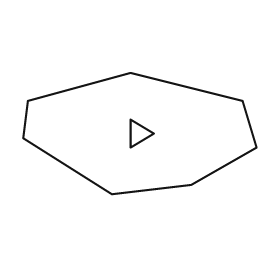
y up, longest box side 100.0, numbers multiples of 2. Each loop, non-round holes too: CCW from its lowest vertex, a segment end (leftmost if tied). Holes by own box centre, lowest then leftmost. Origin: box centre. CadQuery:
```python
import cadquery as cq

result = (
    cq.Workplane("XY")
    .moveTo(-12.0, -26.0)
    .lineTo(22.0, -22.0)
    .lineTo(50.0, -6.0)
    .lineTo(44.0, 14.0)
    .lineTo(-4.0, 26.0)
    .lineTo(-48.0, 14.0)
    .lineTo(-50.0, -2.0)
    .close()
    .moveTo(-4.0, -6.0)
    .lineTo(6.0, 0.0)
    .lineTo(-4.0, 6.0)
    .close()
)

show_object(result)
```